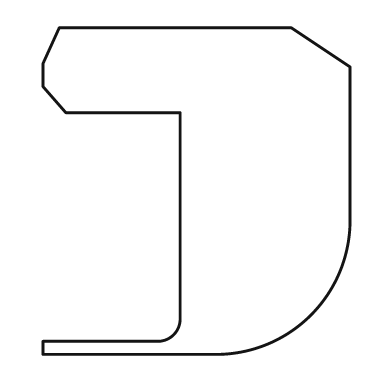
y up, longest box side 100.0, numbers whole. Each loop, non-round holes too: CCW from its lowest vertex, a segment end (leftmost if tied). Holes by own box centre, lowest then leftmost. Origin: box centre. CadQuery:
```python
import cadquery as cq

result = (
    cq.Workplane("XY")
    .moveTo(-47.0, -50.0)
    .lineTo(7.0, -50.0)
    .threePointArc((35.0, -38.0), (47.0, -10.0))
    .lineTo(47.0, 38.0)
    .lineTo(29.0, 50.0)
    .lineTo(-42.0, 50.0)
    .lineTo(-47.0, 39.0)
    .lineTo(-47.0, 32.0)
    .lineTo(-40.0, 24.0)
    .lineTo(-5.0, 24.0)
    .lineTo(-5.0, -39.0)
    .threePointArc((-7.0, -44.0), (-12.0, -46.0))
    .lineTo(-47.0, -46.0)
    .close()
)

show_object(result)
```